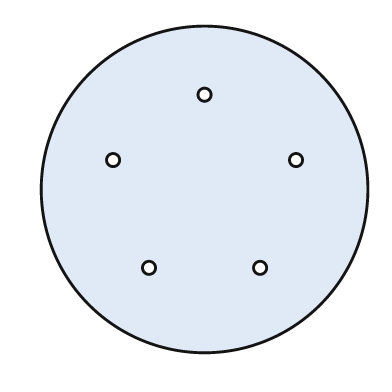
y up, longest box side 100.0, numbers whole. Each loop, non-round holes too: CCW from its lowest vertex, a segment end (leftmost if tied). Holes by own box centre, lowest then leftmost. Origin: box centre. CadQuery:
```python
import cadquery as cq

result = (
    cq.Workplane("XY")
    .moveTo(0.0, 0.0)
    .circle(50.0)
    .moveTo(-17.0, -24.0)
    .circle(2.0)
    .moveTo(17.0, -24.0)
    .circle(2.0)
    .moveTo(-28.0, 9.0)
    .circle(2.0)
    .moveTo(28.0, 9.0)
    .circle(2.0)
    .moveTo(0.0, 29.0)
    .circle(2.0)
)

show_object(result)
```